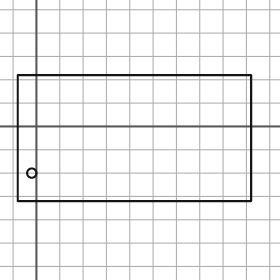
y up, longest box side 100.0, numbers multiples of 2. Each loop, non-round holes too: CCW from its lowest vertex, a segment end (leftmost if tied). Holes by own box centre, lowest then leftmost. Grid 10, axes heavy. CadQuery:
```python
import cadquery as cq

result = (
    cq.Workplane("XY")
    .moveTo(-8.0, -32.0)
    .lineTo(92.0, -32.0)
    .lineTo(92.0, 22.0)
    .lineTo(-8.0, 22.0)
    .close()
    .moveTo(-2.0, -20.0)
    .circle(2.0)
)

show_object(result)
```